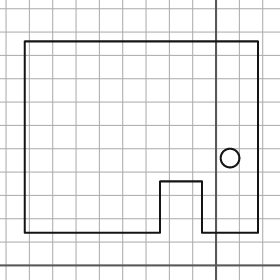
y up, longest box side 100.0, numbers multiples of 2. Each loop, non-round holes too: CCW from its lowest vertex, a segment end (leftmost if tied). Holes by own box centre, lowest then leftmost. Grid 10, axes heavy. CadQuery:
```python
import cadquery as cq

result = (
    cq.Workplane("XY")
    .moveTo(-82.0, 14.0)
    .lineTo(-24.0, 14.0)
    .lineTo(-24.0, 36.0)
    .lineTo(-6.0, 36.0)
    .lineTo(-6.0, 14.0)
    .lineTo(18.0, 14.0)
    .lineTo(18.0, 96.0)
    .lineTo(-82.0, 96.0)
    .close()
    .moveTo(6.0, 46.0)
    .circle(4.0)
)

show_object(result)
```